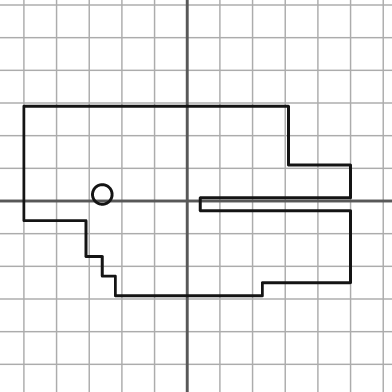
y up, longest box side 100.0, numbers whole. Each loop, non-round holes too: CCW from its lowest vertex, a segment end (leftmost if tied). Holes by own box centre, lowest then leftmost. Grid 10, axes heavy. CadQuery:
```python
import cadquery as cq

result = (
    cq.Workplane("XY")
    .moveTo(-22.0, -29.0)
    .lineTo(23.0, -29.0)
    .lineTo(23.0, -25.0)
    .lineTo(50.0, -25.0)
    .lineTo(50.0, -3.0)
    .lineTo(4.0, -3.0)
    .lineTo(4.0, 1.0)
    .lineTo(50.0, 1.0)
    .lineTo(50.0, 11.0)
    .lineTo(31.0, 11.0)
    .lineTo(31.0, 29.0)
    .lineTo(-50.0, 29.0)
    .lineTo(-50.0, -6.0)
    .lineTo(-31.0, -6.0)
    .lineTo(-31.0, -17.0)
    .lineTo(-26.0, -17.0)
    .lineTo(-26.0, -23.0)
    .lineTo(-22.0, -23.0)
    .close()
    .moveTo(-26.0, 2.0)
    .circle(3.0)
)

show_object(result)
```